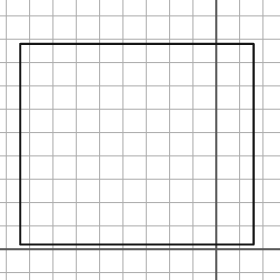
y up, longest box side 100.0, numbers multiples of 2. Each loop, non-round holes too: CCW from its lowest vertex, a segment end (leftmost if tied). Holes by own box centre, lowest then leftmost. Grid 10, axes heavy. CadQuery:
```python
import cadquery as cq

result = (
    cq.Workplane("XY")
    .moveTo(-84.0, 2.0)
    .lineTo(16.0, 2.0)
    .lineTo(16.0, 88.0)
    .lineTo(-84.0, 88.0)
    .close()
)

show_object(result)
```